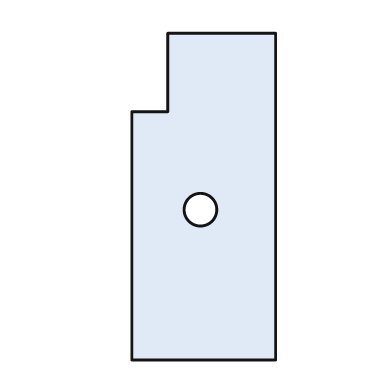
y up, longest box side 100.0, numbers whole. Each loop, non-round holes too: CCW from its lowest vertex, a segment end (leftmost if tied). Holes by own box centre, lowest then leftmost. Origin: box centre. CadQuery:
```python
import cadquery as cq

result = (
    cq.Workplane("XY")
    .moveTo(-22.0, -50.0)
    .lineTo(22.0, -50.0)
    .lineTo(22.0, 50.0)
    .lineTo(-11.0, 50.0)
    .lineTo(-11.0, 26.0)
    .lineTo(-22.0, 26.0)
    .close()
    .moveTo(-1.0, -4.0)
    .circle(5.0)
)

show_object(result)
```